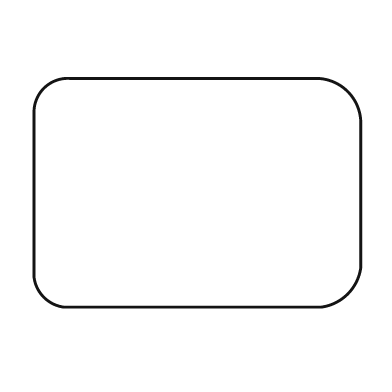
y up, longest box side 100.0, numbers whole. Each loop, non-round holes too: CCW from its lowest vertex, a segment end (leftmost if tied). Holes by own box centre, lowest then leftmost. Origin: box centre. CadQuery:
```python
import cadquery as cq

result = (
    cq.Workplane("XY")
    .moveTo(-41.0, -35.0)
    .lineTo(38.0, -35.0)
    .threePointArc((46.0, -31.0), (50.0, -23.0))
    .lineTo(50.0, 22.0)
    .threePointArc((46.0, 31.0), (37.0, 35.0))
    .lineTo(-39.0, 35.0)
    .threePointArc((-47.0, 32.0), (-50.0, 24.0))
    .lineTo(-50.0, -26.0)
    .threePointArc((-47.0, -32.0), (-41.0, -35.0))
    .close()
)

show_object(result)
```